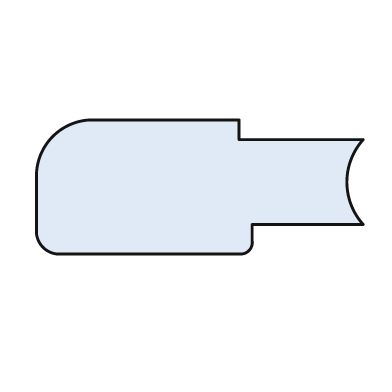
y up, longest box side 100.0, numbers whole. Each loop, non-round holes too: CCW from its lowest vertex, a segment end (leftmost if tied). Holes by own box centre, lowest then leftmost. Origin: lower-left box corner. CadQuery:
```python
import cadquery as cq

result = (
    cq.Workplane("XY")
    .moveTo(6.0, 0.0)
    .lineTo(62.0, 0.0)
    .threePointArc((65.0, 1.0), (66.0, 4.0))
    .lineTo(66.0, 9.0)
    .lineTo(100.0, 9.0)
    .threePointArc((95.0, 22.0), (100.0, 35.0))
    .lineTo(62.0, 35.0)
    .lineTo(62.0, 41.0)
    .lineTo(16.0, 41.0)
    .threePointArc((5.0, 36.0), (0.0, 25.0))
    .lineTo(0.0, 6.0)
    .threePointArc((2.0, 2.0), (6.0, 0.0))
    .close()
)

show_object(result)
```